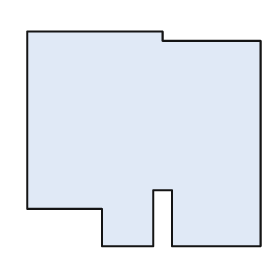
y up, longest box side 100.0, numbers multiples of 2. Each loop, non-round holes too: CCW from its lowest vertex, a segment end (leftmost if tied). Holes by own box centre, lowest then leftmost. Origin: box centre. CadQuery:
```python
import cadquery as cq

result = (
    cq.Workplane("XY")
    .moveTo(-18.0, -46.0)
    .lineTo(4.0, -46.0)
    .lineTo(4.0, -22.0)
    .lineTo(12.0, -22.0)
    .lineTo(12.0, -46.0)
    .lineTo(50.0, -46.0)
    .lineTo(50.0, 42.0)
    .lineTo(8.0, 42.0)
    .lineTo(8.0, 46.0)
    .lineTo(-50.0, 46.0)
    .lineTo(-50.0, -30.0)
    .lineTo(-18.0, -30.0)
    .close()
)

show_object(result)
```